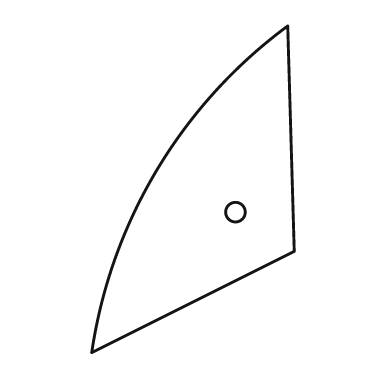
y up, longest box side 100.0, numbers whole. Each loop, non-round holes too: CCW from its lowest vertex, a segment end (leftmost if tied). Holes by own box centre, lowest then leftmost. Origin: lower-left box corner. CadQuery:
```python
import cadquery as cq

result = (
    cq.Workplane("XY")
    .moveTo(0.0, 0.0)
    .lineTo(62.0, 31.0)
    .lineTo(60.0, 100.0)
    .threePointArc((20.0, 56.0), (0.0, 0.0))
    .close()
    .moveTo(44.0, 43.0)
    .circle(3.0)
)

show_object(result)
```